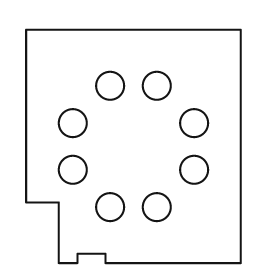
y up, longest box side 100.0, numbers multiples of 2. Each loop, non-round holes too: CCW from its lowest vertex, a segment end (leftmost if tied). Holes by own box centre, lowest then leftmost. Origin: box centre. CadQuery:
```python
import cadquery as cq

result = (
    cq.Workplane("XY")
    .moveTo(-32.0, -50.0)
    .lineTo(-24.0, -50.0)
    .lineTo(-24.0, -46.0)
    .lineTo(-12.0, -46.0)
    .lineTo(-12.0, -50.0)
    .lineTo(46.0, -50.0)
    .lineTo(46.0, 50.0)
    .lineTo(-46.0, 50.0)
    .lineTo(-46.0, -24.0)
    .lineTo(-32.0, -24.0)
    .close()
    .moveTo(-10.0, -26.0)
    .circle(6.0)
    .moveTo(10.0, -26.0)
    .circle(6.0)
    .moveTo(-26.0, -10.0)
    .circle(6.0)
    .moveTo(26.0, -10.0)
    .circle(6.0)
    .moveTo(-26.0, 10.0)
    .circle(6.0)
    .moveTo(26.0, 10.0)
    .circle(6.0)
    .moveTo(-10.0, 26.0)
    .circle(6.0)
    .moveTo(10.0, 26.0)
    .circle(6.0)
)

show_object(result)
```